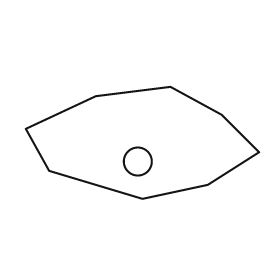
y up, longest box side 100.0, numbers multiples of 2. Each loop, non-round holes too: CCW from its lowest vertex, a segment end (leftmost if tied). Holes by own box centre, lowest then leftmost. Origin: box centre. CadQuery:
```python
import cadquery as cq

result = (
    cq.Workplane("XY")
    .moveTo(0.0, -24.0)
    .lineTo(28.0, -18.0)
    .lineTo(50.0, -4.0)
    .lineTo(34.0, 12.0)
    .lineTo(12.0, 24.0)
    .lineTo(-20.0, 20.0)
    .lineTo(-50.0, 6.0)
    .lineTo(-40.0, -12.0)
    .close()
    .moveTo(-2.0, -8.0)
    .circle(6.0)
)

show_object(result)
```